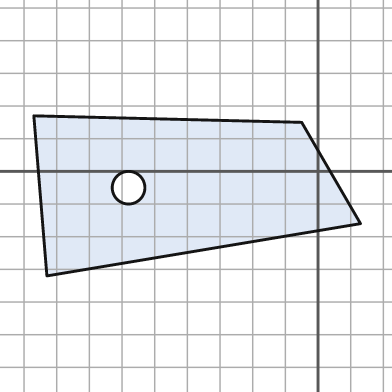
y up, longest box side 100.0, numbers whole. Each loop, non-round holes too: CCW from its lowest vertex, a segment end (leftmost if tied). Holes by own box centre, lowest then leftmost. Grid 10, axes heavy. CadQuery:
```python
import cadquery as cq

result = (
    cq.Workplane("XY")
    .moveTo(-83.0, -32.0)
    .lineTo(13.0, -16.0)
    .lineTo(-5.0, 15.0)
    .lineTo(-87.0, 17.0)
    .close()
    .moveTo(-58.0, -5.0)
    .circle(5.0)
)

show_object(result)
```